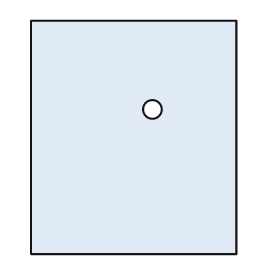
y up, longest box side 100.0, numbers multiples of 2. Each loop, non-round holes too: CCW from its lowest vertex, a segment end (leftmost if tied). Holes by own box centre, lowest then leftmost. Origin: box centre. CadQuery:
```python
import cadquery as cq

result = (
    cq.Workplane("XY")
    .moveTo(-44.0, -50.0)
    .lineTo(44.0, -50.0)
    .lineTo(44.0, 50.0)
    .lineTo(-44.0, 50.0)
    .close()
    .moveTo(8.0, 12.0)
    .circle(4.0)
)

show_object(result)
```